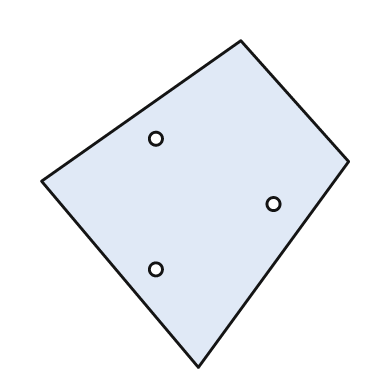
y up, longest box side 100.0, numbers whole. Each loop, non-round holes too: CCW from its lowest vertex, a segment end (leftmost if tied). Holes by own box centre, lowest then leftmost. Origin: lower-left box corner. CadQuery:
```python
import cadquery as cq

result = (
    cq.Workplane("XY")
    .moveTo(48.0, 0.0)
    .lineTo(94.0, 63.0)
    .lineTo(61.0, 100.0)
    .lineTo(0.0, 57.0)
    .close()
    .moveTo(35.0, 30.0)
    .circle(2.0)
    .moveTo(71.0, 50.0)
    .circle(2.0)
    .moveTo(35.0, 70.0)
    .circle(2.0)
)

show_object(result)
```